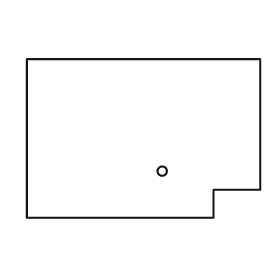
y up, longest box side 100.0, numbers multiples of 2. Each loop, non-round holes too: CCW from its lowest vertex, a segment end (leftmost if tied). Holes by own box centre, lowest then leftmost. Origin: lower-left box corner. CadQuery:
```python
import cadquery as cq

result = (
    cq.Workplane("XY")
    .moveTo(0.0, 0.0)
    .lineTo(80.0, 0.0)
    .lineTo(80.0, 12.0)
    .lineTo(100.0, 12.0)
    .lineTo(100.0, 68.0)
    .lineTo(0.0, 68.0)
    .close()
    .moveTo(58.0, 20.0)
    .circle(2.0)
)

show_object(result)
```